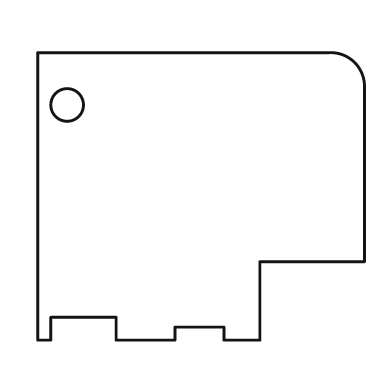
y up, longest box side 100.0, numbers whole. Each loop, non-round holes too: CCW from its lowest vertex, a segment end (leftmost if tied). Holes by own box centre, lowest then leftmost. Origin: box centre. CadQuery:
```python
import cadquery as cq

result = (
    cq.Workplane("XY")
    .moveTo(-50.0, -44.0)
    .lineTo(-46.0, -44.0)
    .lineTo(-46.0, -37.0)
    .lineTo(-26.0, -37.0)
    .lineTo(-26.0, -44.0)
    .lineTo(-8.0, -44.0)
    .lineTo(-8.0, -40.0)
    .lineTo(7.0, -40.0)
    .lineTo(7.0, -44.0)
    .lineTo(18.0, -44.0)
    .lineTo(18.0, -20.0)
    .lineTo(50.0, -20.0)
    .lineTo(50.0, 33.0)
    .threePointArc((47.0, 41.0), (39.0, 44.0))
    .lineTo(-50.0, 44.0)
    .close()
    .moveTo(-41.0, 28.0)
    .circle(5.0)
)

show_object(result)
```